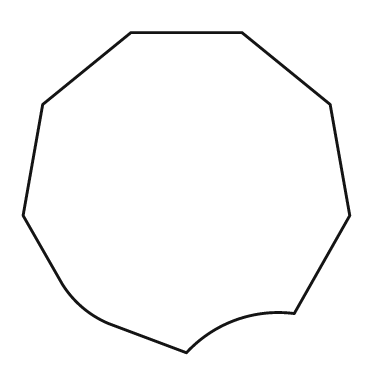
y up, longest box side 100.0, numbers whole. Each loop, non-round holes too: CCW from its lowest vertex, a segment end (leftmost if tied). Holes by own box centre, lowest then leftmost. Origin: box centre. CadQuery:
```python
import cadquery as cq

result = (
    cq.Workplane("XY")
    .moveTo(0.0, -49.0)
    .threePointArc((15.0, -39.0), (33.0, -37.0))
    .lineTo(50.0, -7.0)
    .lineTo(44.0, 27.0)
    .lineTo(17.0, 49.0)
    .lineTo(-17.0, 49.0)
    .lineTo(-44.0, 27.0)
    .lineTo(-50.0, -7.0)
    .lineTo(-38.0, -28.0)
    .threePointArc((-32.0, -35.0), (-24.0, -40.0))
    .close()
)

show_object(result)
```